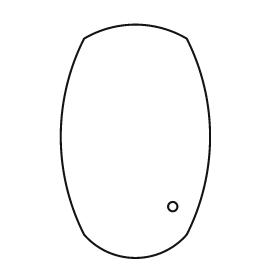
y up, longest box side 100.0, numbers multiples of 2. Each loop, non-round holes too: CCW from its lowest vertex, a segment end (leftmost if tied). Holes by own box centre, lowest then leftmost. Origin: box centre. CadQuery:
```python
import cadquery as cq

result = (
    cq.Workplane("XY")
    .moveTo(-22.0, -40.0)
    .threePointArc((0.0, -50.0), (22.0, -40.0))
    .threePointArc((32.0, 2.0), (22.0, 44.0))
    .threePointArc((0.0, 50.0), (-22.0, 44.0))
    .threePointArc((-32.0, 2.0), (-22.0, -40.0))
    .close()
    .moveTo(16.0, -28.0)
    .circle(2.0)
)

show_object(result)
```